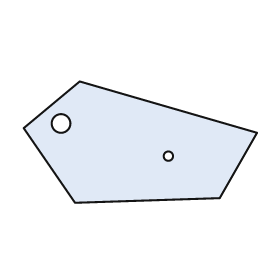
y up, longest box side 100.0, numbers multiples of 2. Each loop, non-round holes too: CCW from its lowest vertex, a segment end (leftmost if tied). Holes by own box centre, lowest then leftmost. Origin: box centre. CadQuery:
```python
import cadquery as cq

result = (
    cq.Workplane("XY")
    .moveTo(-28.0, -26.0)
    .lineTo(34.0, -24.0)
    .lineTo(50.0, 4.0)
    .lineTo(-26.0, 26.0)
    .lineTo(-50.0, 6.0)
    .close()
    .moveTo(12.0, -6.0)
    .circle(2.0)
    .moveTo(-34.0, 8.0)
    .circle(4.0)
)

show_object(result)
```